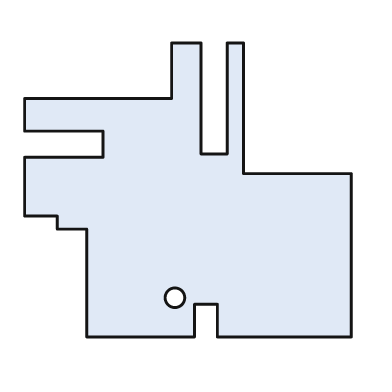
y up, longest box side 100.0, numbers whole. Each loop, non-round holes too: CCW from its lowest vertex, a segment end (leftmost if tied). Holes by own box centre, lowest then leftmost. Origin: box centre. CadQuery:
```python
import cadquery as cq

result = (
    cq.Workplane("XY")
    .moveTo(-31.0, -45.0)
    .lineTo(2.0, -45.0)
    .lineTo(2.0, -35.0)
    .lineTo(9.0, -35.0)
    .lineTo(9.0, -45.0)
    .lineTo(50.0, -45.0)
    .lineTo(50.0, 5.0)
    .lineTo(17.0, 5.0)
    .lineTo(17.0, 45.0)
    .lineTo(12.0, 45.0)
    .lineTo(12.0, 11.0)
    .lineTo(4.0, 11.0)
    .lineTo(4.0, 45.0)
    .lineTo(-5.0, 45.0)
    .lineTo(-5.0, 28.0)
    .lineTo(-50.0, 28.0)
    .lineTo(-50.0, 18.0)
    .lineTo(-26.0, 18.0)
    .lineTo(-26.0, 10.0)
    .lineTo(-50.0, 10.0)
    .lineTo(-50.0, -8.0)
    .lineTo(-40.0, -8.0)
    .lineTo(-40.0, -12.0)
    .lineTo(-31.0, -12.0)
    .close()
    .moveTo(-4.0, -33.0)
    .circle(3.0)
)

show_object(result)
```